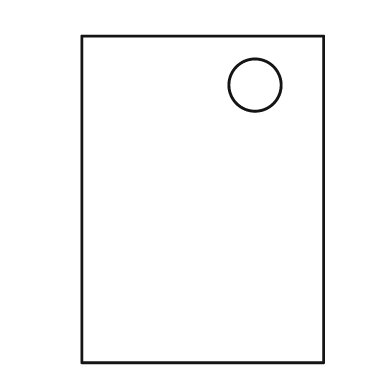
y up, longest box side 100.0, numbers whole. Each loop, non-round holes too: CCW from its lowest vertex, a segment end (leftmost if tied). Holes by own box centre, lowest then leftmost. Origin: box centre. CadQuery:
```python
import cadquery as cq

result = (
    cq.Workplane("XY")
    .moveTo(-37.0, -50.0)
    .lineTo(37.0, -50.0)
    .lineTo(37.0, 50.0)
    .lineTo(-37.0, 50.0)
    .close()
    .moveTo(16.0, 35.0)
    .circle(8.0)
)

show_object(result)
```